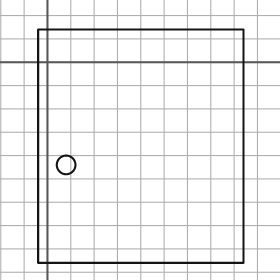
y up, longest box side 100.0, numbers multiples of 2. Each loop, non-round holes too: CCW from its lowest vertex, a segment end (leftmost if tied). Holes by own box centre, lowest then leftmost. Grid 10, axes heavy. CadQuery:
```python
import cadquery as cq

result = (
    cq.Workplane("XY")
    .moveTo(-4.0, -86.0)
    .lineTo(84.0, -86.0)
    .lineTo(84.0, 14.0)
    .lineTo(-4.0, 14.0)
    .close()
    .moveTo(8.0, -44.0)
    .circle(4.0)
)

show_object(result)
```